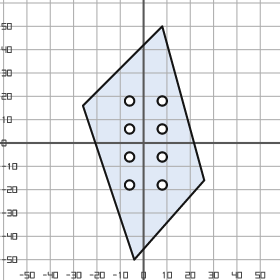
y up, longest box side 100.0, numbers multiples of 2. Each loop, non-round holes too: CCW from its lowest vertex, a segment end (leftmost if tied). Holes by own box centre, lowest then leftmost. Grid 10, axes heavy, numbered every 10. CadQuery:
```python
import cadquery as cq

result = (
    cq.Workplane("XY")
    .moveTo(-4.0, -50.0)
    .lineTo(26.0, -16.0)
    .lineTo(8.0, 50.0)
    .lineTo(-26.0, 16.0)
    .close()
    .moveTo(-6.0, -18.0)
    .circle(2.0)
    .moveTo(8.0, -18.0)
    .circle(2.0)
    .moveTo(-6.0, -6.0)
    .circle(2.0)
    .moveTo(8.0, -6.0)
    .circle(2.0)
    .moveTo(-6.0, 6.0)
    .circle(2.0)
    .moveTo(8.0, 6.0)
    .circle(2.0)
    .moveTo(-6.0, 18.0)
    .circle(2.0)
    .moveTo(8.0, 18.0)
    .circle(2.0)
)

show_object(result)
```